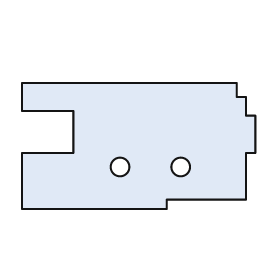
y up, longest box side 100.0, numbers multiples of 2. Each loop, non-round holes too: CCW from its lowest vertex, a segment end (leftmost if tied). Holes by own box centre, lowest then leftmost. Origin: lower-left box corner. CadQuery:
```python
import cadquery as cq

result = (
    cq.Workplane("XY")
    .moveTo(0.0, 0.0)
    .lineTo(62.0, 0.0)
    .lineTo(62.0, 4.0)
    .lineTo(96.0, 4.0)
    .lineTo(96.0, 24.0)
    .lineTo(100.0, 24.0)
    .lineTo(100.0, 40.0)
    .lineTo(96.0, 40.0)
    .lineTo(96.0, 48.0)
    .lineTo(92.0, 48.0)
    .lineTo(92.0, 54.0)
    .lineTo(0.0, 54.0)
    .lineTo(0.0, 42.0)
    .lineTo(22.0, 42.0)
    .lineTo(22.0, 24.0)
    .lineTo(0.0, 24.0)
    .close()
    .moveTo(42.0, 18.0)
    .circle(4.0)
    .moveTo(68.0, 18.0)
    .circle(4.0)
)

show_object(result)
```